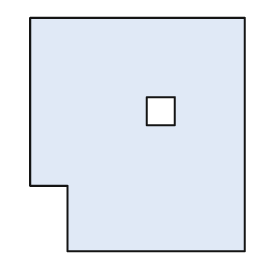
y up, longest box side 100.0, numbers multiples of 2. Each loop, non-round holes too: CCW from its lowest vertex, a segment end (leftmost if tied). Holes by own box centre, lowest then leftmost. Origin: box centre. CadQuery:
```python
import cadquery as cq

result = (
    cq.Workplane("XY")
    .moveTo(-30.0, -50.0)
    .lineTo(46.0, -50.0)
    .lineTo(46.0, 50.0)
    .lineTo(-46.0, 50.0)
    .lineTo(-46.0, -22.0)
    .lineTo(-30.0, -22.0)
    .close()
    .moveTo(4.0, 4.0)
    .lineTo(16.0, 4.0)
    .lineTo(16.0, 16.0)
    .lineTo(4.0, 16.0)
    .close()
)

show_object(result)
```